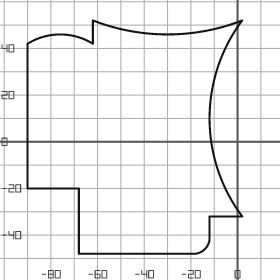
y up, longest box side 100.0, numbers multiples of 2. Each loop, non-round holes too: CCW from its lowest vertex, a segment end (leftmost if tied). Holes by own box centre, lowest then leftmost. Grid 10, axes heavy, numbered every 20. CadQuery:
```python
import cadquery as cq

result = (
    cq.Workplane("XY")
    .moveTo(-68.0, -48.0)
    .lineTo(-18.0, -48.0)
    .threePointArc((-14.0, -46.0), (-12.0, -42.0))
    .lineTo(-12.0, -32.0)
    .lineTo(2.0, -32.0)
    .threePointArc((-12.0, 10.0), (2.0, 52.0))
    .threePointArc((-30.0, 46.0), (-62.0, 52.0))
    .lineTo(-62.0, 42.0)
    .threePointArc((-76.0, 46.0), (-90.0, 42.0))
    .lineTo(-90.0, -20.0)
    .lineTo(-68.0, -20.0)
    .close()
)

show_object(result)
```